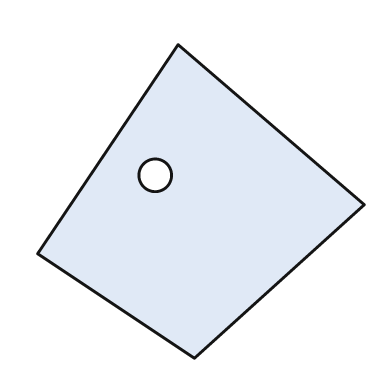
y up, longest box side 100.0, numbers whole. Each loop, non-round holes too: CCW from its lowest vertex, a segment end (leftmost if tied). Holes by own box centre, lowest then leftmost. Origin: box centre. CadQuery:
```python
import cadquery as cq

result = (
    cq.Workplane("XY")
    .moveTo(-2.0, -48.0)
    .lineTo(50.0, -1.0)
    .lineTo(-7.0, 48.0)
    .lineTo(-50.0, -16.0)
    .close()
    .moveTo(-14.0, 8.0)
    .circle(5.0)
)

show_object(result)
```